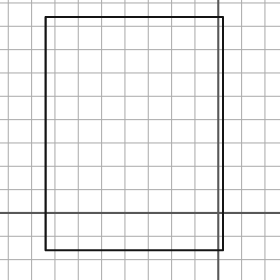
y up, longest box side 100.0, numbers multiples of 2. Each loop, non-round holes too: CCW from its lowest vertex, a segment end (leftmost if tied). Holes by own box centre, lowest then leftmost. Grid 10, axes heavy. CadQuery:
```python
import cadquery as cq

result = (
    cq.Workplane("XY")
    .moveTo(-74.0, -16.0)
    .lineTo(2.0, -16.0)
    .lineTo(2.0, 84.0)
    .lineTo(-74.0, 84.0)
    .close()
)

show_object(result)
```